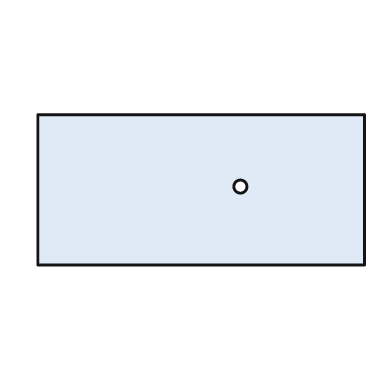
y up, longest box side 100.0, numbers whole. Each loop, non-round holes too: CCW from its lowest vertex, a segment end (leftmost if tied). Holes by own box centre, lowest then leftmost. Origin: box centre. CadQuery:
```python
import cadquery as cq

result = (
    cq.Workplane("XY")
    .moveTo(-50.0, -23.0)
    .lineTo(50.0, -23.0)
    .lineTo(50.0, 23.0)
    .lineTo(-50.0, 23.0)
    .close()
    .moveTo(12.0, 1.0)
    .circle(2.0)
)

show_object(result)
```